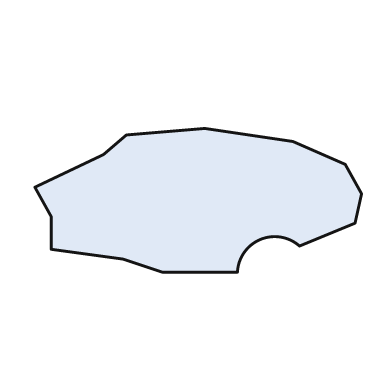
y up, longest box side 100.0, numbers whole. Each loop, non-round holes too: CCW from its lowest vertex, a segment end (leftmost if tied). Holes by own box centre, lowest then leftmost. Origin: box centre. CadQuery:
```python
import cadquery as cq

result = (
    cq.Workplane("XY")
    .moveTo(-11.0, -22.0)
    .lineTo(12.0, -22.0)
    .threePointArc((19.0, -12.0), (31.0, -14.0))
    .lineTo(48.0, -7.0)
    .lineTo(50.0, 2.0)
    .lineTo(45.0, 11.0)
    .lineTo(29.0, 18.0)
    .lineTo(2.0, 22.0)
    .lineTo(-22.0, 20.0)
    .lineTo(-29.0, 14.0)
    .lineTo(-50.0, 4.0)
    .lineTo(-45.0, -5.0)
    .lineTo(-45.0, -15.0)
    .lineTo(-23.0, -18.0)
    .close()
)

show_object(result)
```